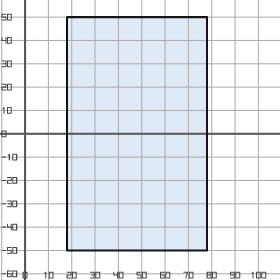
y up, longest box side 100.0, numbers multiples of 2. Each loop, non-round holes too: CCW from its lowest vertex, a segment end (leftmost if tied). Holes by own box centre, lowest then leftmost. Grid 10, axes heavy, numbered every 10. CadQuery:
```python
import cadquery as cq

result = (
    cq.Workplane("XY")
    .moveTo(18.0, -50.0)
    .lineTo(78.0, -50.0)
    .lineTo(78.0, 50.0)
    .lineTo(18.0, 50.0)
    .close()
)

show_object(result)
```